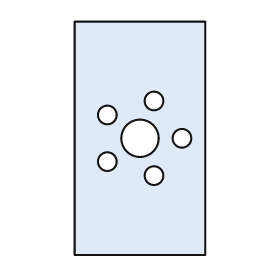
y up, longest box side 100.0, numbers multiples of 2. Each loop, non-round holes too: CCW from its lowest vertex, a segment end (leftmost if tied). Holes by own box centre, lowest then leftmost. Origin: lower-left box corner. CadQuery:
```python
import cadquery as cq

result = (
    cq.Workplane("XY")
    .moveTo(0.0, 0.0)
    .lineTo(56.0, 0.0)
    .lineTo(56.0, 100.0)
    .lineTo(0.0, 100.0)
    .close()
    .moveTo(34.0, 34.0)
    .circle(4.0)
    .moveTo(14.0, 40.0)
    .circle(4.0)
    .moveTo(28.0, 50.0)
    .circle(8.0)
    .moveTo(46.0, 50.0)
    .circle(4.0)
    .moveTo(14.0, 60.0)
    .circle(4.0)
    .moveTo(34.0, 66.0)
    .circle(4.0)
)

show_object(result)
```